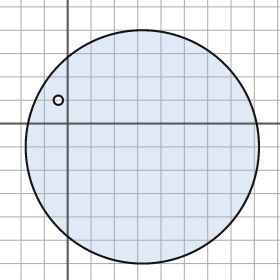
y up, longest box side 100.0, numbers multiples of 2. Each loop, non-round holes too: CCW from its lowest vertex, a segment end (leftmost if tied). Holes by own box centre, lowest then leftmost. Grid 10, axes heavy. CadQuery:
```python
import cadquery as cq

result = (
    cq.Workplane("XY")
    .moveTo(32.0, -10.0)
    .circle(50.0)
    .moveTo(-4.0, 10.0)
    .circle(2.0)
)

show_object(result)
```